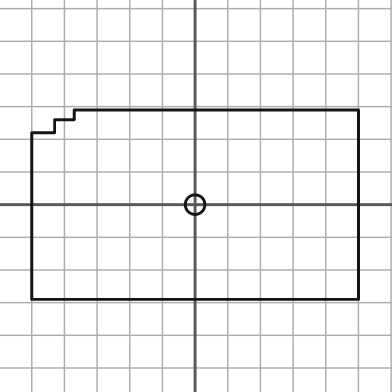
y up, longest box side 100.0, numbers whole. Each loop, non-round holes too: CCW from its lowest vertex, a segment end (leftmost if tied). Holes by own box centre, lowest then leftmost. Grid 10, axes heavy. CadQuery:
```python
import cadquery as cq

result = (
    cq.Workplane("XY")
    .moveTo(-50.0, -29.0)
    .lineTo(50.0, -29.0)
    .lineTo(50.0, 29.0)
    .lineTo(-37.0, 29.0)
    .lineTo(-37.0, 26.0)
    .lineTo(-43.0, 26.0)
    .lineTo(-43.0, 22.0)
    .lineTo(-50.0, 22.0)
    .close()
    .moveTo(0.0, 0.0)
    .circle(3.0)
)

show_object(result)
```